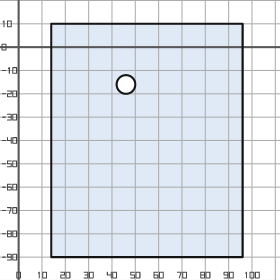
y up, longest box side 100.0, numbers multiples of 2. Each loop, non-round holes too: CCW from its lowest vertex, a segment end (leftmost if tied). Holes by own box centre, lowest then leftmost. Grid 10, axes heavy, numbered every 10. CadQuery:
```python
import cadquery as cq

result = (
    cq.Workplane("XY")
    .moveTo(14.0, -90.0)
    .lineTo(96.0, -90.0)
    .lineTo(96.0, 10.0)
    .lineTo(14.0, 10.0)
    .close()
    .moveTo(46.0, -16.0)
    .circle(4.0)
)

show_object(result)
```